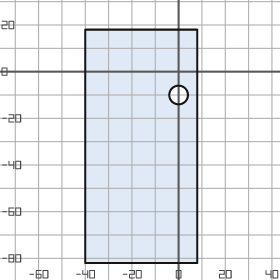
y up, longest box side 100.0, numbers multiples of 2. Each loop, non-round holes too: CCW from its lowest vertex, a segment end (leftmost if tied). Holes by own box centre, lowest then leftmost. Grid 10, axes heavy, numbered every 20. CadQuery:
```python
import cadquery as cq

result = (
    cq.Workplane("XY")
    .moveTo(-40.0, -82.0)
    .lineTo(8.0, -82.0)
    .lineTo(8.0, 18.0)
    .lineTo(-40.0, 18.0)
    .close()
    .moveTo(0.0, -10.0)
    .circle(4.0)
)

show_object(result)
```